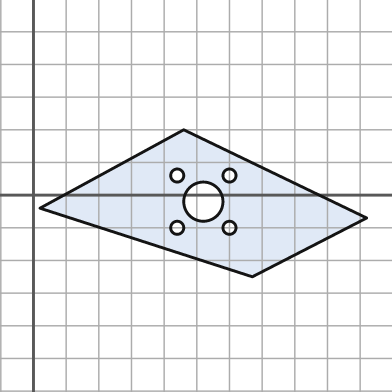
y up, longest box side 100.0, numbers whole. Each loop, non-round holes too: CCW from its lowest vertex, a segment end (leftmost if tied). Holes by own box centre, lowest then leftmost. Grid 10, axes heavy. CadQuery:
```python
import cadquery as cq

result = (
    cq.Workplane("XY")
    .moveTo(67.0, -25.0)
    .lineTo(102.0, -7.0)
    .lineTo(46.0, 20.0)
    .lineTo(2.0, -4.0)
    .close()
    .moveTo(44.0, -10.0)
    .circle(2.0)
    .moveTo(60.0, -10.0)
    .circle(2.0)
    .moveTo(52.0, -2.0)
    .circle(6.0)
    .moveTo(44.0, 6.0)
    .circle(2.0)
    .moveTo(60.0, 6.0)
    .circle(2.0)
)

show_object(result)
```